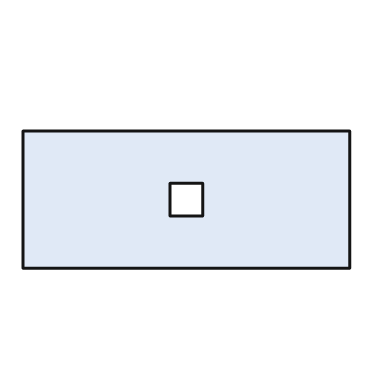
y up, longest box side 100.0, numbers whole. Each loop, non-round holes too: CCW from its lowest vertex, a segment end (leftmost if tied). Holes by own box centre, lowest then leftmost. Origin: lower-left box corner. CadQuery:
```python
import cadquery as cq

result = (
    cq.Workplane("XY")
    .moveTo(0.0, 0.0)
    .lineTo(100.0, 0.0)
    .lineTo(100.0, 42.0)
    .lineTo(0.0, 42.0)
    .close()
    .moveTo(45.0, 16.0)
    .lineTo(55.0, 16.0)
    .lineTo(55.0, 26.0)
    .lineTo(45.0, 26.0)
    .close()
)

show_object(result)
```